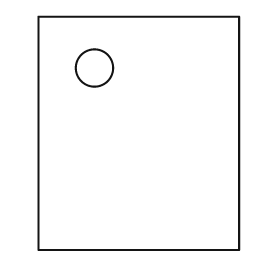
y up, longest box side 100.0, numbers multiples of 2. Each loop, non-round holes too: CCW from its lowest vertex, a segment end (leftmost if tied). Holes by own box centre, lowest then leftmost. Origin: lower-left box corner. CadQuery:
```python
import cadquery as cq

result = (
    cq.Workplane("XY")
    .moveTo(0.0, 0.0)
    .lineTo(86.0, 0.0)
    .lineTo(86.0, 100.0)
    .lineTo(0.0, 100.0)
    .close()
    .moveTo(24.0, 78.0)
    .circle(8.0)
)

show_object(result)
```